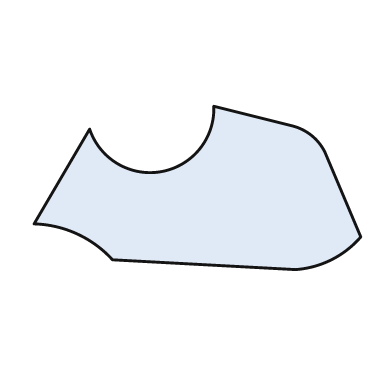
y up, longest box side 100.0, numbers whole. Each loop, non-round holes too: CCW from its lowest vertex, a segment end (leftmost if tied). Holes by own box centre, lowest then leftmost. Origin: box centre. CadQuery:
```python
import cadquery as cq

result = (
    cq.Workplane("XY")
    .moveTo(30.0, -25.0)
    .threePointArc((41.0, -22.0), (50.0, -15.0))
    .lineTo(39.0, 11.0)
    .threePointArc((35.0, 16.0), (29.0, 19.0))
    .lineTo(5.0, 25.0)
    .threePointArc((-11.0, 5.0), (-33.0, 18.0))
    .lineTo(-50.0, -11.0)
    .threePointArc((-37.0, -14.0), (-26.0, -22.0))
    .close()
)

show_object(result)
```